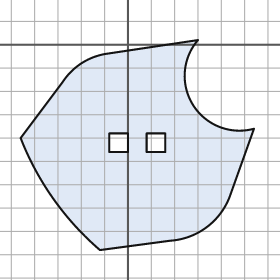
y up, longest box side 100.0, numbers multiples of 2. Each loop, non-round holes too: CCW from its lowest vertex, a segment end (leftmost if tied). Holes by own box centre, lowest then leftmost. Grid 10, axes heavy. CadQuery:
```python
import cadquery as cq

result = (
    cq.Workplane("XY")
    .moveTo(-12.0, -88.0)
    .lineTo(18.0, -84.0)
    .threePointArc((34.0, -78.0), (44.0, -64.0))
    .lineTo(54.0, -36.0)
    .threePointArc((28.0, -26.0), (30.0, 2.0))
    .lineTo(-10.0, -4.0)
    .threePointArc((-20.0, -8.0), (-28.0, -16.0))
    .lineTo(-46.0, -40.0)
    .threePointArc((-32.0, -66.0), (-12.0, -88.0))
    .close()
    .moveTo(-8.0, -46.0)
    .lineTo(0.0, -46.0)
    .lineTo(0.0, -38.0)
    .lineTo(-8.0, -38.0)
    .close()
    .moveTo(8.0, -46.0)
    .lineTo(16.0, -46.0)
    .lineTo(16.0, -38.0)
    .lineTo(8.0, -38.0)
    .close()
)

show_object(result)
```